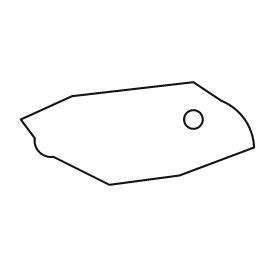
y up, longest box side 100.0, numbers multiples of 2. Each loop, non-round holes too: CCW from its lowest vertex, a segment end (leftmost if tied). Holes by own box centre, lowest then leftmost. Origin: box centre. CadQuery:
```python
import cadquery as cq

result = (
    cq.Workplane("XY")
    .moveTo(-12.0, -22.0)
    .lineTo(18.0, -18.0)
    .lineTo(50.0, -6.0)
    .threePointArc((46.0, 6.0), (36.0, 14.0))
    .lineTo(24.0, 22.0)
    .lineTo(-28.0, 16.0)
    .lineTo(-50.0, 6.0)
    .lineTo(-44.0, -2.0)
    .threePointArc((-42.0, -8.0), (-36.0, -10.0))
    .close()
    .moveTo(24.0, 6.0)
    .circle(4.0)
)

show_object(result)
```